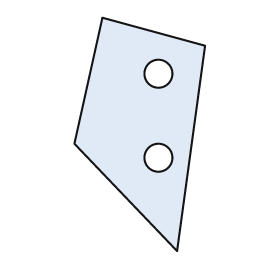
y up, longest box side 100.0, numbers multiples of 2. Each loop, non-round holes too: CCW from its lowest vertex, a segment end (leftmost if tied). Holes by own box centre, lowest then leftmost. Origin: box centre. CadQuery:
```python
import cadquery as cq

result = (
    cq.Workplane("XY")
    .moveTo(16.0, -50.0)
    .lineTo(28.0, 38.0)
    .lineTo(-16.0, 50.0)
    .lineTo(-28.0, -4.0)
    .close()
    .moveTo(8.0, -10.0)
    .circle(6.0)
    .moveTo(8.0, 26.0)
    .circle(6.0)
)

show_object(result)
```